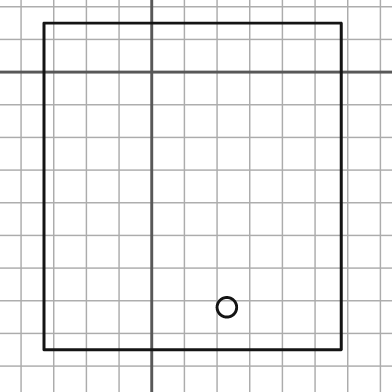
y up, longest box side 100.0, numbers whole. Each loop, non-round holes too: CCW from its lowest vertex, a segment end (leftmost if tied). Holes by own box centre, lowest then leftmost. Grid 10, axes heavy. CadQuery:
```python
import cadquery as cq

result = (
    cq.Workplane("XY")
    .moveTo(-33.0, -85.0)
    .lineTo(58.0, -85.0)
    .lineTo(58.0, 15.0)
    .lineTo(-33.0, 15.0)
    .close()
    .moveTo(23.0, -72.0)
    .circle(3.0)
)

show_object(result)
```